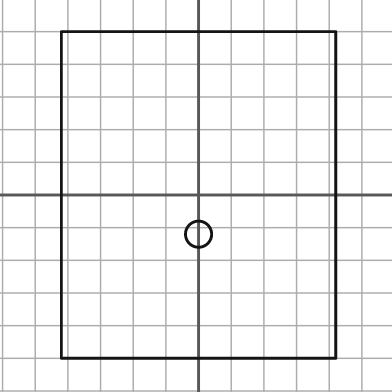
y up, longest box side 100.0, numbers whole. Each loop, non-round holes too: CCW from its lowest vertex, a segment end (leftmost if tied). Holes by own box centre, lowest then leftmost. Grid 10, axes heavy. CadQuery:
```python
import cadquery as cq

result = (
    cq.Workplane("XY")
    .moveTo(-42.0, -50.0)
    .lineTo(42.0, -50.0)
    .lineTo(42.0, 50.0)
    .lineTo(-42.0, 50.0)
    .close()
    .moveTo(0.0, -12.0)
    .circle(4.0)
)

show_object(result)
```